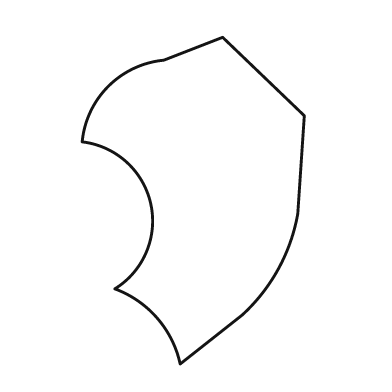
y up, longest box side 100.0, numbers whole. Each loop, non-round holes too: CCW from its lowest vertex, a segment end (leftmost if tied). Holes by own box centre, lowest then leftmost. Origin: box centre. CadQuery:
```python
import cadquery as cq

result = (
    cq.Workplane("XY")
    .moveTo(-4.0, -50.0)
    .lineTo(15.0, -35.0)
    .threePointArc((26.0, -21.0), (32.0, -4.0))
    .lineTo(34.0, 26.0)
    .lineTo(9.0, 50.0)
    .lineTo(-9.0, 43.0)
    .threePointArc((-26.0, 35.0), (-34.0, 18.0))
    .threePointArc((-13.0, -1.0), (-24.0, -27.0))
    .threePointArc((-11.0, -36.0), (-4.0, -50.0))
    .close()
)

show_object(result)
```